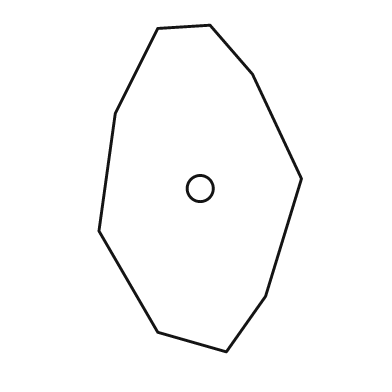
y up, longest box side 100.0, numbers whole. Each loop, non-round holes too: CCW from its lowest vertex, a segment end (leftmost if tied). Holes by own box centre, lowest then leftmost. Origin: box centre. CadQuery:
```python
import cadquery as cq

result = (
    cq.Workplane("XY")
    .moveTo(8.0, -50.0)
    .lineTo(20.0, -33.0)
    .lineTo(31.0, 3.0)
    .lineTo(16.0, 35.0)
    .lineTo(3.0, 50.0)
    .lineTo(-13.0, 49.0)
    .lineTo(-26.0, 23.0)
    .lineTo(-31.0, -13.0)
    .lineTo(-13.0, -44.0)
    .close()
    .moveTo(0.0, 0.0)
    .circle(4.0)
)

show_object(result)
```